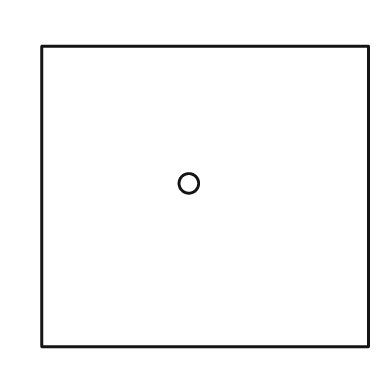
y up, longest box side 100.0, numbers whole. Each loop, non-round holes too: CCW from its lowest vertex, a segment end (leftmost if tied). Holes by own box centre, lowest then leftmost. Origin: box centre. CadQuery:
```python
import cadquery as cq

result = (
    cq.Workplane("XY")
    .moveTo(-50.0, -46.0)
    .lineTo(50.0, -46.0)
    .lineTo(50.0, 46.0)
    .lineTo(-50.0, 46.0)
    .close()
    .moveTo(-5.0, 4.0)
    .circle(3.0)
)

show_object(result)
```